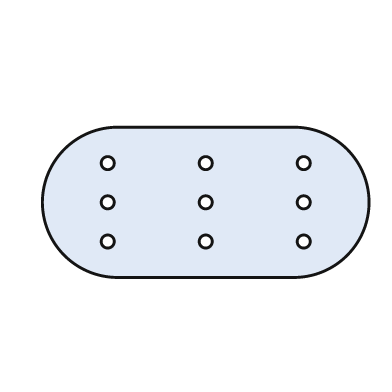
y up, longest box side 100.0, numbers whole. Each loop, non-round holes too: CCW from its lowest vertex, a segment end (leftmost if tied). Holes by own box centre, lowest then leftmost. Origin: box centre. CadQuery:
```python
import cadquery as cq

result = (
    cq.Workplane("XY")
    .moveTo(-27.0, -23.0)
    .lineTo(27.0, -23.0)
    .threePointArc((50.0, 0.0), (27.0, 23.0))
    .lineTo(-27.0, 23.0)
    .threePointArc((-50.0, 0.0), (-27.0, -23.0))
    .close()
    .moveTo(-30.0, -12.0)
    .circle(2.0)
    .moveTo(0.0, -12.0)
    .circle(2.0)
    .moveTo(30.0, -12.0)
    .circle(2.0)
    .moveTo(-30.0, 0.0)
    .circle(2.0)
    .moveTo(0.0, 0.0)
    .circle(2.0)
    .moveTo(30.0, 0.0)
    .circle(2.0)
    .moveTo(-30.0, 12.0)
    .circle(2.0)
    .moveTo(0.0, 12.0)
    .circle(2.0)
    .moveTo(30.0, 12.0)
    .circle(2.0)
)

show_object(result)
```